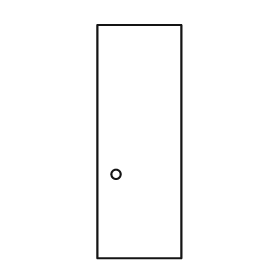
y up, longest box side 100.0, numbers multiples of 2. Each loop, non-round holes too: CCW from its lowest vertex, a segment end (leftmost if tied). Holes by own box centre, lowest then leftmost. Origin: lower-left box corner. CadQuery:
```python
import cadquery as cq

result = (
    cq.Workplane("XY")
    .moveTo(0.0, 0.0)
    .lineTo(36.0, 0.0)
    .lineTo(36.0, 100.0)
    .lineTo(0.0, 100.0)
    .close()
    .moveTo(8.0, 36.0)
    .circle(2.0)
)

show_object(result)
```